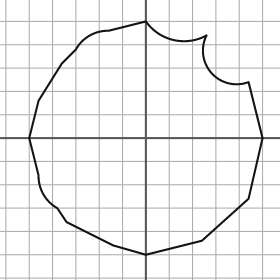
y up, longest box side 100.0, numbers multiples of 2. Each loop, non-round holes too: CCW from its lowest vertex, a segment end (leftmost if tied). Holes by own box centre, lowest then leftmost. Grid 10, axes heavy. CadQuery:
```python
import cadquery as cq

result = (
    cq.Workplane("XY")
    .moveTo(0.0, -50.0)
    .lineTo(24.0, -44.0)
    .lineTo(44.0, -26.0)
    .lineTo(50.0, 0.0)
    .lineTo(44.0, 24.0)
    .threePointArc((28.0, 28.0), (26.0, 44.0))
    .threePointArc((12.0, 42.0), (0.0, 50.0))
    .lineTo(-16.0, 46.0)
    .threePointArc((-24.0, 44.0), (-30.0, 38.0))
    .lineTo(-36.0, 32.0)
    .lineTo(-46.0, 16.0)
    .lineTo(-50.0, 0.0)
    .lineTo(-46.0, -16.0)
    .threePointArc((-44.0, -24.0), (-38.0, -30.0))
    .lineTo(-34.0, -36.0)
    .lineTo(-14.0, -46.0)
    .close()
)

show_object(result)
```